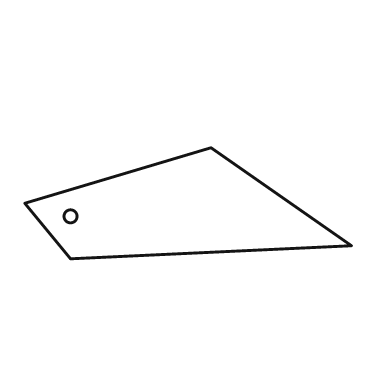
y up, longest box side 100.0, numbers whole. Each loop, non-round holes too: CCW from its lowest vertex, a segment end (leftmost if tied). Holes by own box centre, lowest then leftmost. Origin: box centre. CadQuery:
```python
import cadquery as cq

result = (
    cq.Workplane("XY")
    .moveTo(-36.0, -17.0)
    .lineTo(50.0, -13.0)
    .lineTo(7.0, 17.0)
    .lineTo(-50.0, 0.0)
    .close()
    .moveTo(-36.0, -4.0)
    .circle(2.0)
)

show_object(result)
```